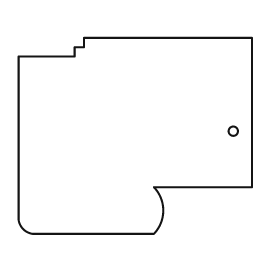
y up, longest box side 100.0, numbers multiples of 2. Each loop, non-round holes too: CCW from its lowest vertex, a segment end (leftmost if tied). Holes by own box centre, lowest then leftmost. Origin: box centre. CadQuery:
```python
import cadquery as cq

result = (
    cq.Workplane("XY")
    .moveTo(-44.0, -42.0)
    .lineTo(8.0, -42.0)
    .threePointArc((12.0, -32.0), (8.0, -22.0))
    .lineTo(50.0, -22.0)
    .lineTo(50.0, 42.0)
    .lineTo(-22.0, 42.0)
    .lineTo(-22.0, 38.0)
    .lineTo(-26.0, 38.0)
    .lineTo(-26.0, 34.0)
    .lineTo(-50.0, 34.0)
    .lineTo(-50.0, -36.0)
    .threePointArc((-48.0, -40.0), (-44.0, -42.0))
    .close()
    .moveTo(42.0, 2.0)
    .circle(2.0)
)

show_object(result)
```